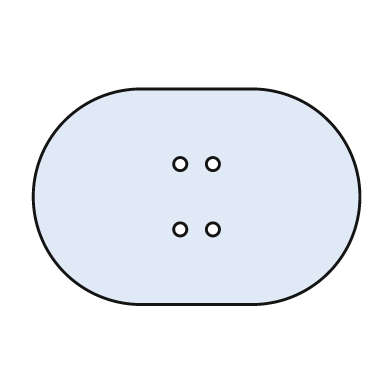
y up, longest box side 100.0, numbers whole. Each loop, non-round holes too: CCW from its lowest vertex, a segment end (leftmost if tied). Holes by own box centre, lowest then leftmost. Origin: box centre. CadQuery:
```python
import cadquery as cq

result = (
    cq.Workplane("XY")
    .moveTo(-17.0, -33.0)
    .lineTo(17.0, -33.0)
    .threePointArc((50.0, 0.0), (17.0, 33.0))
    .lineTo(-17.0, 33.0)
    .threePointArc((-50.0, 0.0), (-17.0, -33.0))
    .close()
    .moveTo(-5.0, -10.0)
    .circle(2.0)
    .moveTo(5.0, -10.0)
    .circle(2.0)
    .moveTo(-5.0, 10.0)
    .circle(2.0)
    .moveTo(5.0, 10.0)
    .circle(2.0)
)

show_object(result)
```